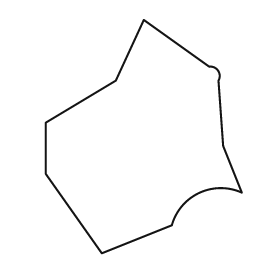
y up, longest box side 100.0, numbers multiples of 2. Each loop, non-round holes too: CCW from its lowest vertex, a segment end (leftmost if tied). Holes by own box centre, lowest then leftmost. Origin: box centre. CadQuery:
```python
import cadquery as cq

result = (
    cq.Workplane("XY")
    .moveTo(-18.0, -50.0)
    .lineTo(12.0, -38.0)
    .threePointArc((24.0, -24.0), (42.0, -24.0))
    .lineTo(34.0, -4.0)
    .lineTo(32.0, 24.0)
    .threePointArc((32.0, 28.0), (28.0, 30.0))
    .lineTo(0.0, 50.0)
    .lineTo(-12.0, 24.0)
    .lineTo(-42.0, 6.0)
    .lineTo(-42.0, -16.0)
    .close()
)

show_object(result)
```